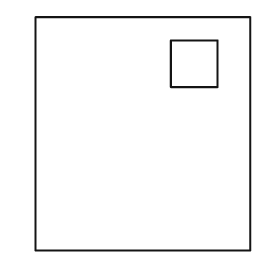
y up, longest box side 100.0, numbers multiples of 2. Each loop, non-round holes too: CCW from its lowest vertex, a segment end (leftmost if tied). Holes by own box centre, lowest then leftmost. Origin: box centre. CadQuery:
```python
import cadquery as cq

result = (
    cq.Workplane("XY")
    .moveTo(-46.0, -50.0)
    .lineTo(46.0, -50.0)
    .lineTo(46.0, 50.0)
    .lineTo(-46.0, 50.0)
    .close()
    .moveTo(12.0, 20.0)
    .lineTo(32.0, 20.0)
    .lineTo(32.0, 40.0)
    .lineTo(12.0, 40.0)
    .close()
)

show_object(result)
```